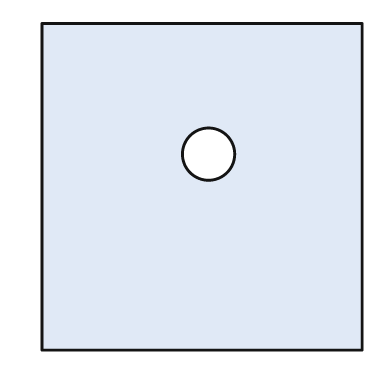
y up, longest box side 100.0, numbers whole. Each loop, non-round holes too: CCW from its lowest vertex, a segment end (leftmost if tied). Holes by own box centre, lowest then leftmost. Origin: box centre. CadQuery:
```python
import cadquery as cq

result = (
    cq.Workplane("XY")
    .moveTo(-49.0, -50.0)
    .lineTo(49.0, -50.0)
    .lineTo(49.0, 50.0)
    .lineTo(-49.0, 50.0)
    .close()
    .moveTo(2.0, 10.0)
    .circle(8.0)
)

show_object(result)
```